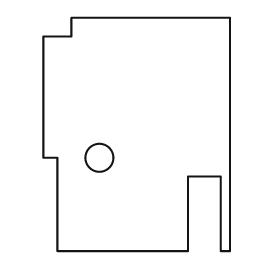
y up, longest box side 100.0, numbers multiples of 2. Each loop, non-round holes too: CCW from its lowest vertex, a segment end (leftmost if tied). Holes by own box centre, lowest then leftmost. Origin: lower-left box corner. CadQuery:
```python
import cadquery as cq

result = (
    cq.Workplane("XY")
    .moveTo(6.0, 0.0)
    .lineTo(62.0, 0.0)
    .lineTo(62.0, 32.0)
    .lineTo(76.0, 32.0)
    .lineTo(76.0, 0.0)
    .lineTo(80.0, 0.0)
    .lineTo(80.0, 100.0)
    .lineTo(12.0, 100.0)
    .lineTo(12.0, 92.0)
    .lineTo(0.0, 92.0)
    .lineTo(0.0, 40.0)
    .lineTo(6.0, 40.0)
    .close()
    .moveTo(24.0, 40.0)
    .circle(6.0)
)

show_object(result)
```